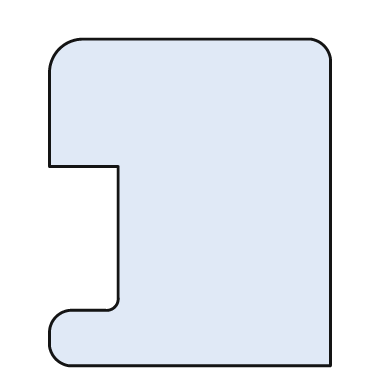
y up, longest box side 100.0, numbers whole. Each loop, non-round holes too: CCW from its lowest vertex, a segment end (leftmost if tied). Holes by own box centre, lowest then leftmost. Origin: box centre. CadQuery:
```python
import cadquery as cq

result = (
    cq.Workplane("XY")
    .moveTo(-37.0, -50.0)
    .lineTo(43.0, -50.0)
    .lineTo(43.0, 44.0)
    .threePointArc((41.0, 48.0), (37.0, 50.0))
    .lineTo(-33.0, 50.0)
    .threePointArc((-40.0, 47.0), (-43.0, 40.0))
    .lineTo(-43.0, 11.0)
    .lineTo(-22.0, 11.0)
    .lineTo(-22.0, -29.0)
    .threePointArc((-23.0, -32.0), (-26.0, -33.0))
    .lineTo(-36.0, -33.0)
    .threePointArc((-41.0, -35.0), (-43.0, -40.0))
    .lineTo(-43.0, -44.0)
    .threePointArc((-41.0, -48.0), (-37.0, -50.0))
    .close()
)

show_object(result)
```